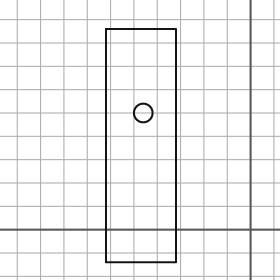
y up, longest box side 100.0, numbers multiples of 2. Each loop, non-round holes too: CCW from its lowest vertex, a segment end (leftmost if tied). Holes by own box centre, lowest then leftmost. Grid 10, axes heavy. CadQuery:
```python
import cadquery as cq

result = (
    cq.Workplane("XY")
    .moveTo(-62.0, -14.0)
    .lineTo(-32.0, -14.0)
    .lineTo(-32.0, 86.0)
    .lineTo(-62.0, 86.0)
    .close()
    .moveTo(-46.0, 50.0)
    .circle(4.0)
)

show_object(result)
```